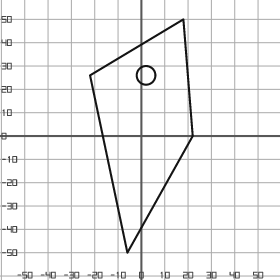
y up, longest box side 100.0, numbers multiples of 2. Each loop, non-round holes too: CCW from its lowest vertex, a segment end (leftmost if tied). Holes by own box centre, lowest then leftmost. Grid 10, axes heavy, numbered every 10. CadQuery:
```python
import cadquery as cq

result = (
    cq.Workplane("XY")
    .moveTo(-6.0, -50.0)
    .lineTo(22.0, 0.0)
    .lineTo(18.0, 50.0)
    .lineTo(-22.0, 26.0)
    .close()
    .moveTo(2.0, 26.0)
    .circle(4.0)
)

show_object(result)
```